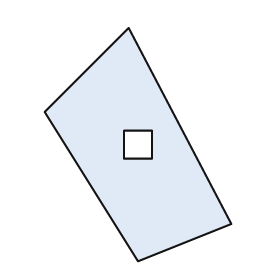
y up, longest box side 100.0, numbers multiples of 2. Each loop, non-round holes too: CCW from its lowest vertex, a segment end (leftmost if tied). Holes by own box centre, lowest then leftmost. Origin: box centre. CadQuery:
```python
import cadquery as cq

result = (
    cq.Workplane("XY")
    .moveTo(0.0, -50.0)
    .lineTo(40.0, -34.0)
    .lineTo(-4.0, 50.0)
    .lineTo(-40.0, 14.0)
    .close()
    .moveTo(-6.0, -6.0)
    .lineTo(6.0, -6.0)
    .lineTo(6.0, 6.0)
    .lineTo(-6.0, 6.0)
    .close()
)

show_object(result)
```